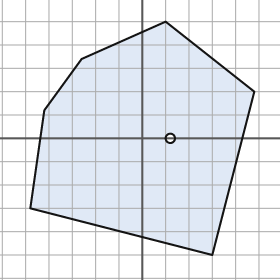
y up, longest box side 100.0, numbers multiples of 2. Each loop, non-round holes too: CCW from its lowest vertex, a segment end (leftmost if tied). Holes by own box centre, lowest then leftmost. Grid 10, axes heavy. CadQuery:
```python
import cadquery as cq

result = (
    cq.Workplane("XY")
    .moveTo(30.0, -50.0)
    .lineTo(48.0, 20.0)
    .lineTo(10.0, 50.0)
    .lineTo(-26.0, 34.0)
    .lineTo(-42.0, 12.0)
    .lineTo(-48.0, -30.0)
    .close()
    .moveTo(12.0, 0.0)
    .circle(2.0)
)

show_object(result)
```